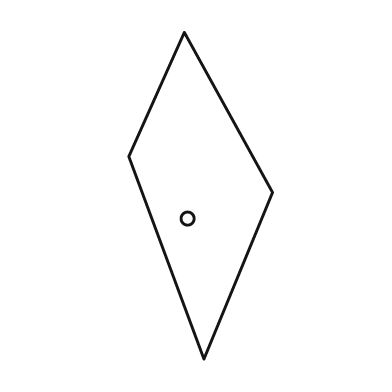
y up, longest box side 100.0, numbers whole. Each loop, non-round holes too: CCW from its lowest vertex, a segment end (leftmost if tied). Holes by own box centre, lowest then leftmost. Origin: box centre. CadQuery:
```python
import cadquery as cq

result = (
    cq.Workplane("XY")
    .moveTo(1.0, -50.0)
    .lineTo(22.0, 1.0)
    .lineTo(-5.0, 50.0)
    .lineTo(-22.0, 12.0)
    .close()
    .moveTo(-4.0, -7.0)
    .circle(2.0)
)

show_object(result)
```